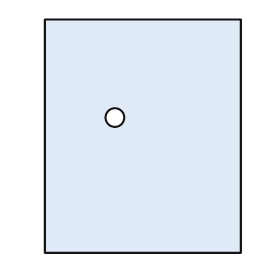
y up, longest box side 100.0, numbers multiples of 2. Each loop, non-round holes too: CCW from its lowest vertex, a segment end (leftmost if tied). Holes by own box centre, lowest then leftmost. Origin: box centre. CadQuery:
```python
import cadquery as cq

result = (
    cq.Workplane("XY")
    .moveTo(-42.0, -50.0)
    .lineTo(42.0, -50.0)
    .lineTo(42.0, 50.0)
    .lineTo(-42.0, 50.0)
    .close()
    .moveTo(-12.0, 8.0)
    .circle(4.0)
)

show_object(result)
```